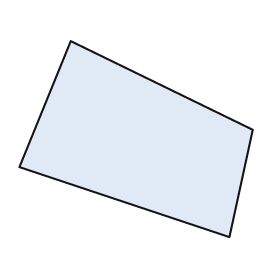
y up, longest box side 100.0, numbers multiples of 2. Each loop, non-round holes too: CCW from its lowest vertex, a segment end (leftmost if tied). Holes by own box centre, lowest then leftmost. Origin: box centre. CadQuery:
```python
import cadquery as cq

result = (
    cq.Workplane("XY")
    .moveTo(40.0, -42.0)
    .lineTo(50.0, 4.0)
    .lineTo(-28.0, 42.0)
    .lineTo(-50.0, -12.0)
    .close()
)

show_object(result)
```